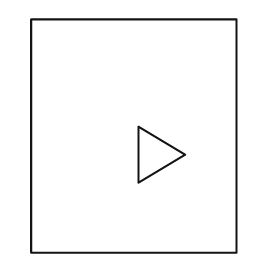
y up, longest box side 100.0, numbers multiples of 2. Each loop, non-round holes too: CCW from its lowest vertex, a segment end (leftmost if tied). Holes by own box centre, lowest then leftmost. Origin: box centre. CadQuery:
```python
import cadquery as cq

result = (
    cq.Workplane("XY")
    .moveTo(-44.0, -50.0)
    .lineTo(44.0, -50.0)
    .lineTo(44.0, 50.0)
    .lineTo(-44.0, 50.0)
    .close()
    .moveTo(2.0, -20.0)
    .lineTo(22.0, -8.0)
    .lineTo(2.0, 4.0)
    .close()
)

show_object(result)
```